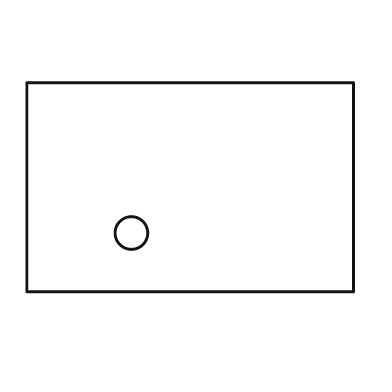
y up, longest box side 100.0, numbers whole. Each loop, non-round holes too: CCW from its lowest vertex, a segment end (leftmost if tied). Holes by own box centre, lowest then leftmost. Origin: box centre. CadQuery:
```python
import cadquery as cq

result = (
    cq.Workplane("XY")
    .moveTo(-50.0, -32.0)
    .lineTo(50.0, -32.0)
    .lineTo(50.0, 32.0)
    .lineTo(-50.0, 32.0)
    .close()
    .moveTo(-18.0, -14.0)
    .circle(5.0)
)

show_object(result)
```